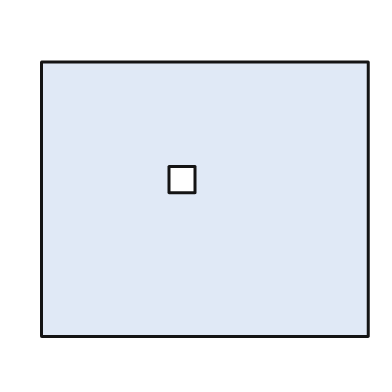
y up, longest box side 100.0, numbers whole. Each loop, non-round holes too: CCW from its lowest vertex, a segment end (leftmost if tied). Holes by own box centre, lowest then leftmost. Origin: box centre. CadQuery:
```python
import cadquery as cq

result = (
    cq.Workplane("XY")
    .moveTo(-50.0, -42.0)
    .lineTo(50.0, -42.0)
    .lineTo(50.0, 42.0)
    .lineTo(-50.0, 42.0)
    .close()
    .moveTo(-11.0, 2.0)
    .lineTo(-3.0, 2.0)
    .lineTo(-3.0, 10.0)
    .lineTo(-11.0, 10.0)
    .close()
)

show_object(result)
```